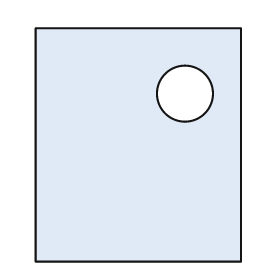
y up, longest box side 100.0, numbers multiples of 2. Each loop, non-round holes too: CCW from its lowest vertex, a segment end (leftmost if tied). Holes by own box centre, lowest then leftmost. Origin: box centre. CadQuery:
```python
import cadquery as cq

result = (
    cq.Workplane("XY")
    .moveTo(-44.0, -50.0)
    .lineTo(44.0, -50.0)
    .lineTo(44.0, 50.0)
    .lineTo(-44.0, 50.0)
    .close()
    .moveTo(20.0, 22.0)
    .circle(12.0)
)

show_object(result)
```